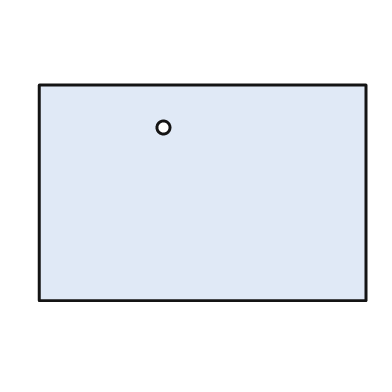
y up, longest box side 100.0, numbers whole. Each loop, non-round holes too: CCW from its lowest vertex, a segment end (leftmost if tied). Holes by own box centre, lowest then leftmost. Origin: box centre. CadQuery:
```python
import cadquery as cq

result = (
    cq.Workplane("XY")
    .moveTo(-50.0, -33.0)
    .lineTo(50.0, -33.0)
    .lineTo(50.0, 33.0)
    .lineTo(-50.0, 33.0)
    .close()
    .moveTo(-12.0, 20.0)
    .circle(2.0)
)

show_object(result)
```